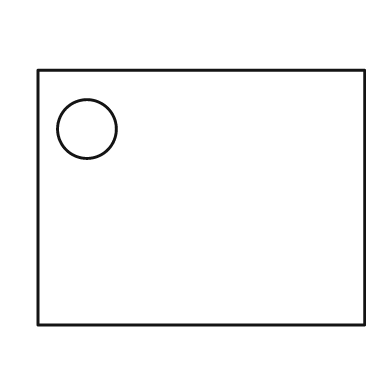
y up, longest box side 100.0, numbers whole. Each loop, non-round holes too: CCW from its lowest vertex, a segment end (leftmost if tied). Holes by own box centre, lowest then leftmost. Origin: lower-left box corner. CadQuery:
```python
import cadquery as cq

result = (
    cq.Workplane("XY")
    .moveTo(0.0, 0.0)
    .lineTo(100.0, 0.0)
    .lineTo(100.0, 78.0)
    .lineTo(0.0, 78.0)
    .close()
    .moveTo(15.0, 60.0)
    .circle(9.0)
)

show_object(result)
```